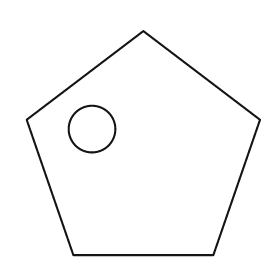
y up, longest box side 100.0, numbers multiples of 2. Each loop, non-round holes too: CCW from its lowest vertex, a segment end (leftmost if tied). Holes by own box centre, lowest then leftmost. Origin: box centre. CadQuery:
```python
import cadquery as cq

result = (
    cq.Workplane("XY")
    .moveTo(-30.0, -48.0)
    .lineTo(30.0, -48.0)
    .lineTo(50.0, 10.0)
    .lineTo(0.0, 48.0)
    .lineTo(-50.0, 10.0)
    .close()
    .moveTo(-22.0, 6.0)
    .circle(10.0)
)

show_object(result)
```